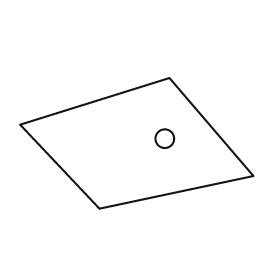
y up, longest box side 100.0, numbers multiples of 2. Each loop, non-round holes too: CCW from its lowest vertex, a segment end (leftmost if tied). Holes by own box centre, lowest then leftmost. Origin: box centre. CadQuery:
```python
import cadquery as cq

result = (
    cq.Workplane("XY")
    .moveTo(-16.0, -28.0)
    .lineTo(50.0, -14.0)
    .lineTo(14.0, 28.0)
    .lineTo(-50.0, 8.0)
    .close()
    .moveTo(12.0, 2.0)
    .circle(4.0)
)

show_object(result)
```